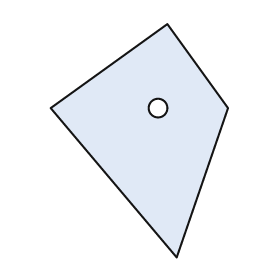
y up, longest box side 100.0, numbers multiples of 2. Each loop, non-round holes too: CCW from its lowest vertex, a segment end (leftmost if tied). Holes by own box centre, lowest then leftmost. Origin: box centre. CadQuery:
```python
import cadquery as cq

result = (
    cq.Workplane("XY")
    .moveTo(16.0, -50.0)
    .lineTo(38.0, 14.0)
    .lineTo(12.0, 50.0)
    .lineTo(-38.0, 14.0)
    .close()
    .moveTo(8.0, 14.0)
    .circle(4.0)
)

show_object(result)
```